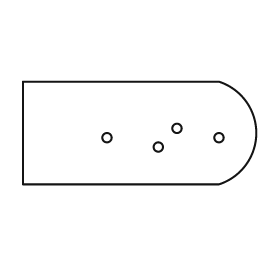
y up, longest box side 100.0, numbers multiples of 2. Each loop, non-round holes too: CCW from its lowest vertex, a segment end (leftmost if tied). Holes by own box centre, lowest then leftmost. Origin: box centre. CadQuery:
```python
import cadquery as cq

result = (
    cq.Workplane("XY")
    .moveTo(-50.0, -22.0)
    .lineTo(34.0, -22.0)
    .threePointArc((50.0, 0.0), (34.0, 22.0))
    .lineTo(-50.0, 22.0)
    .close()
    .moveTo(8.0, -6.0)
    .circle(2.0)
    .moveTo(-14.0, -2.0)
    .circle(2.0)
    .moveTo(34.0, -2.0)
    .circle(2.0)
    .moveTo(16.0, 2.0)
    .circle(2.0)
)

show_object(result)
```